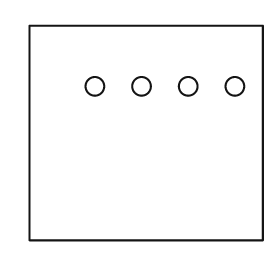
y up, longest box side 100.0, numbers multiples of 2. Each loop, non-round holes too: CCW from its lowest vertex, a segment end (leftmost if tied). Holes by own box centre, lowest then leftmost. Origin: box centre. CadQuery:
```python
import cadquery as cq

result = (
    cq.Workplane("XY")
    .moveTo(-50.0, -46.0)
    .lineTo(50.0, -46.0)
    .lineTo(50.0, 46.0)
    .lineTo(-50.0, 46.0)
    .close()
    .moveTo(-22.0, 20.0)
    .circle(4.0)
    .moveTo(-2.0, 20.0)
    .circle(4.0)
    .moveTo(18.0, 20.0)
    .circle(4.0)
    .moveTo(38.0, 20.0)
    .circle(4.0)
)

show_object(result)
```